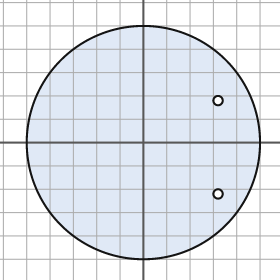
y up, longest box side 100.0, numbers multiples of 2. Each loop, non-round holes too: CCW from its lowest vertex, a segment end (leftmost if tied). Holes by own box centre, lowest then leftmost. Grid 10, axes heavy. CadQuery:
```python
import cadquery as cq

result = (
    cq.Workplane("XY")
    .moveTo(0.0, 0.0)
    .circle(50.0)
    .moveTo(32.0, -22.0)
    .circle(2.0)
    .moveTo(32.0, 18.0)
    .circle(2.0)
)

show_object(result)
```